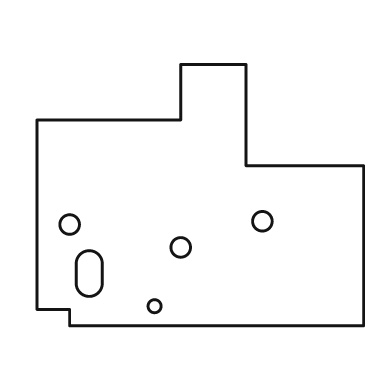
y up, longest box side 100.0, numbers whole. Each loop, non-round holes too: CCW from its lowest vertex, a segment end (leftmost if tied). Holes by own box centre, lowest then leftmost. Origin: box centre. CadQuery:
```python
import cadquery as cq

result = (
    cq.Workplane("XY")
    .moveTo(-40.0, -40.0)
    .lineTo(50.0, -40.0)
    .lineTo(50.0, 9.0)
    .lineTo(14.0, 9.0)
    .lineTo(14.0, 40.0)
    .lineTo(-6.0, 40.0)
    .lineTo(-6.0, 23.0)
    .lineTo(-50.0, 23.0)
    .lineTo(-50.0, -35.0)
    .lineTo(-40.0, -35.0)
    .close()
    .moveTo(-14.0, -34.0)
    .circle(2.0)
    .moveTo(-38.0, -27.0)
    .threePointArc((-34.0, -31.0), (-30.0, -27.0))
    .lineTo(-30.0, -21.0)
    .threePointArc((-34.0, -17.0), (-38.0, -21.0))
    .close()
    .moveTo(-6.0, -16.0)
    .circle(3.0)
    .moveTo(-40.0, -9.0)
    .circle(3.0)
    .moveTo(19.0, -8.0)
    .circle(3.0)
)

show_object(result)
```